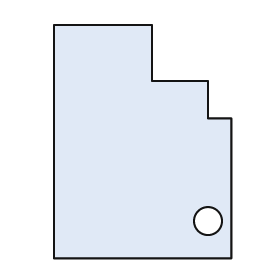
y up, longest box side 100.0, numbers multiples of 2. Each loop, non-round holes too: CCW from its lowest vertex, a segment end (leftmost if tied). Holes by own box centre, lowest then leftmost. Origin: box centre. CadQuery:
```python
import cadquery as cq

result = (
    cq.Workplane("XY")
    .moveTo(-38.0, -50.0)
    .lineTo(38.0, -50.0)
    .lineTo(38.0, 10.0)
    .lineTo(28.0, 10.0)
    .lineTo(28.0, 26.0)
    .lineTo(4.0, 26.0)
    .lineTo(4.0, 50.0)
    .lineTo(-38.0, 50.0)
    .close()
    .moveTo(28.0, -34.0)
    .circle(6.0)
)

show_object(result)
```